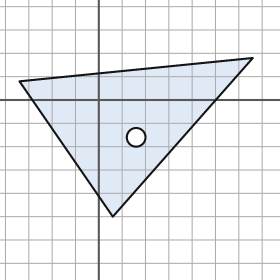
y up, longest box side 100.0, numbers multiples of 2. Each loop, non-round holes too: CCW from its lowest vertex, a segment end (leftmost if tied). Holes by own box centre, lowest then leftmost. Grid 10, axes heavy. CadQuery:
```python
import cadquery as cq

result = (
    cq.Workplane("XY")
    .moveTo(6.0, -50.0)
    .lineTo(66.0, 18.0)
    .lineTo(-34.0, 8.0)
    .close()
    .moveTo(16.0, -16.0)
    .circle(4.0)
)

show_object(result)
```